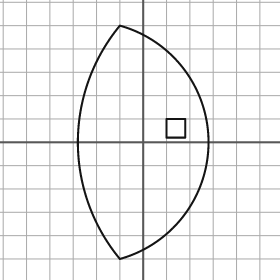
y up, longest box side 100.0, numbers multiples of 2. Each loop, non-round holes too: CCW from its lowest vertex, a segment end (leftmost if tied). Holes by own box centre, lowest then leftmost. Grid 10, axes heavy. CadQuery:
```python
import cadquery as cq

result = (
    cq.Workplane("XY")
    .moveTo(-10.0, -50.0)
    .threePointArc((28.0, 0.0), (-10.0, 50.0))
    .threePointArc((-28.0, 0.0), (-10.0, -50.0))
    .close()
    .moveTo(10.0, 2.0)
    .lineTo(18.0, 2.0)
    .lineTo(18.0, 10.0)
    .lineTo(10.0, 10.0)
    .close()
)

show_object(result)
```